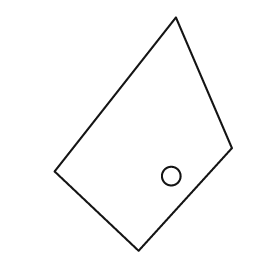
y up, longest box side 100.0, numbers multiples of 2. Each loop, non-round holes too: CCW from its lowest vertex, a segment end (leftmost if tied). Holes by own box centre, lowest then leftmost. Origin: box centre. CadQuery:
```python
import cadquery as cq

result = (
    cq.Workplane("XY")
    .moveTo(-2.0, -50.0)
    .lineTo(38.0, -6.0)
    .lineTo(14.0, 50.0)
    .lineTo(-38.0, -16.0)
    .close()
    .moveTo(12.0, -18.0)
    .circle(4.0)
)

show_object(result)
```